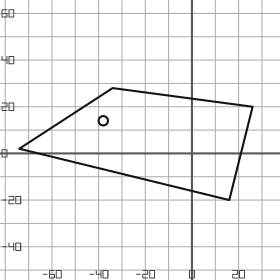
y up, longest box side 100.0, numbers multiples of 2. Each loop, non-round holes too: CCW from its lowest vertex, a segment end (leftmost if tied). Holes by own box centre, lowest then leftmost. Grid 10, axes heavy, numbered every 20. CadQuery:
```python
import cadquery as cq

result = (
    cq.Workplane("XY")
    .moveTo(16.0, -20.0)
    .lineTo(26.0, 20.0)
    .lineTo(-34.0, 28.0)
    .lineTo(-74.0, 2.0)
    .close()
    .moveTo(-38.0, 14.0)
    .circle(2.0)
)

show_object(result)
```